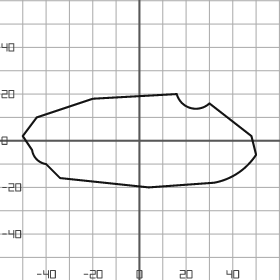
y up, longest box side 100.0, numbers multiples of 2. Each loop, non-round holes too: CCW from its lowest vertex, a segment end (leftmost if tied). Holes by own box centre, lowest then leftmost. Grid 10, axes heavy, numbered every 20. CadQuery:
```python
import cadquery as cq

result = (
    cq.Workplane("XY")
    .moveTo(4.0, -20.0)
    .lineTo(32.0, -18.0)
    .threePointArc((42.0, -14.0), (50.0, -6.0))
    .lineTo(48.0, 2.0)
    .lineTo(30.0, 16.0)
    .threePointArc((22.0, 14.0), (16.0, 20.0))
    .lineTo(-20.0, 18.0)
    .lineTo(-44.0, 10.0)
    .lineTo(-50.0, 2.0)
    .lineTo(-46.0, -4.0)
    .threePointArc((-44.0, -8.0), (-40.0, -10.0))
    .lineTo(-34.0, -16.0)
    .close()
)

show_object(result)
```